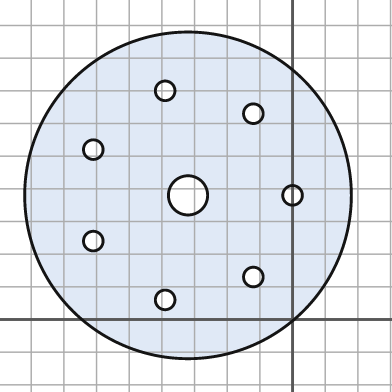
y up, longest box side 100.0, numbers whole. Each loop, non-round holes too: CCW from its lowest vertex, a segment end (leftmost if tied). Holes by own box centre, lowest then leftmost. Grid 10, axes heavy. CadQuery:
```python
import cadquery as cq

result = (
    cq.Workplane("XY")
    .moveTo(-32.0, 38.0)
    .circle(50.0)
    .moveTo(-39.0, 6.0)
    .circle(3.0)
    .moveTo(-12.0, 13.0)
    .circle(3.0)
    .moveTo(-61.0, 24.0)
    .circle(3.0)
    .moveTo(-32.0, 38.0)
    .circle(6.0)
    .moveTo(0.0, 38.0)
    .circle(3.0)
    .moveTo(-61.0, 52.0)
    .circle(3.0)
    .moveTo(-12.0, 63.0)
    .circle(3.0)
    .moveTo(-39.0, 70.0)
    .circle(3.0)
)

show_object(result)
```